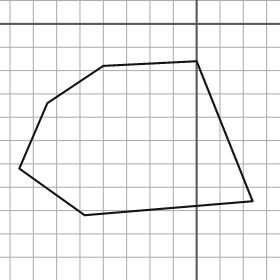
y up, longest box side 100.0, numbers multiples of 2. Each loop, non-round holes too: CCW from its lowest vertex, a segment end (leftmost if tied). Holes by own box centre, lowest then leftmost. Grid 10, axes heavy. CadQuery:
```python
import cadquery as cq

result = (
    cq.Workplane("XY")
    .moveTo(-48.0, -82.0)
    .lineTo(24.0, -76.0)
    .lineTo(0.0, -16.0)
    .lineTo(-40.0, -18.0)
    .lineTo(-64.0, -34.0)
    .lineTo(-76.0, -62.0)
    .close()
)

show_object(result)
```